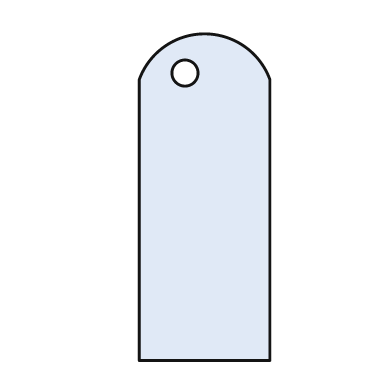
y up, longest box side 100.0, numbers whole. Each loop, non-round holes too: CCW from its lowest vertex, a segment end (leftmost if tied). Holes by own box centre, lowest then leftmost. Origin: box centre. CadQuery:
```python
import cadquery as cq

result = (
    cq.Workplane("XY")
    .moveTo(-20.0, -50.0)
    .lineTo(20.0, -50.0)
    .lineTo(20.0, 36.0)
    .threePointArc((0.0, 50.0), (-20.0, 36.0))
    .close()
    .moveTo(-6.0, 38.0)
    .circle(4.0)
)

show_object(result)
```